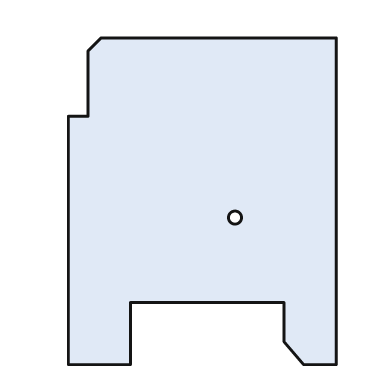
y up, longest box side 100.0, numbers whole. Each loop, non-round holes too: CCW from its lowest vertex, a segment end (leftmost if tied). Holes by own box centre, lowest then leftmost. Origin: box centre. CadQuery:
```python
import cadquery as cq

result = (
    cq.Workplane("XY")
    .moveTo(-41.0, -50.0)
    .lineTo(-22.0, -50.0)
    .lineTo(-22.0, -31.0)
    .lineTo(25.0, -31.0)
    .lineTo(25.0, -43.0)
    .lineTo(31.0, -50.0)
    .lineTo(41.0, -50.0)
    .lineTo(41.0, 50.0)
    .lineTo(-31.0, 50.0)
    .lineTo(-35.0, 46.0)
    .lineTo(-35.0, 26.0)
    .lineTo(-41.0, 26.0)
    .close()
    .moveTo(10.0, -5.0)
    .circle(2.0)
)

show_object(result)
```